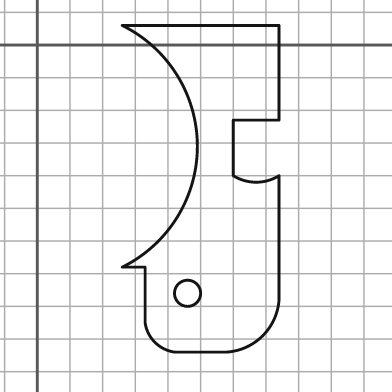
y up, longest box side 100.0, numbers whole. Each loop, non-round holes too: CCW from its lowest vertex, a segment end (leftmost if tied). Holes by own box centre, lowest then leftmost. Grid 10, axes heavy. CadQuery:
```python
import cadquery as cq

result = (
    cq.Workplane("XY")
    .moveTo(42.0, -94.0)
    .lineTo(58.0, -94.0)
    .threePointArc((69.0, -89.0), (74.0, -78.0))
    .lineTo(74.0, -40.0)
    .threePointArc((67.0, -42.0), (60.0, -40.0))
    .lineTo(60.0, -23.0)
    .lineTo(74.0, -23.0)
    .lineTo(74.0, 6.0)
    .lineTo(26.0, 6.0)
    .threePointArc((49.0, -31.0), (26.0, -68.0))
    .lineTo(33.0, -68.0)
    .lineTo(33.0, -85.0)
    .threePointArc((36.0, -91.0), (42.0, -94.0))
    .close()
    .moveTo(46.0, -76.0)
    .circle(4.0)
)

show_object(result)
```